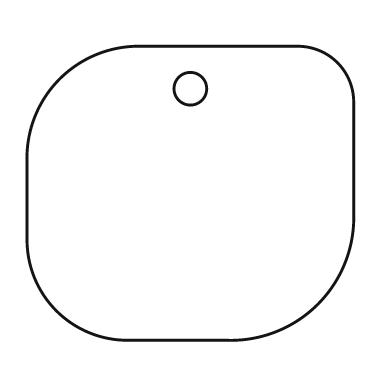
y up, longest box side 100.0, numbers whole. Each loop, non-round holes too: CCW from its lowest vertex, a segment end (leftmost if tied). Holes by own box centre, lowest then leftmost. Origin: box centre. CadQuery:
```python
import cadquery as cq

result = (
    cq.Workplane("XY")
    .moveTo(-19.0, -45.0)
    .lineTo(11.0, -45.0)
    .threePointArc((39.0, -34.0), (50.0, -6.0))
    .lineTo(50.0, 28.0)
    .threePointArc((45.0, 40.0), (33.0, 45.0))
    .lineTo(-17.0, 45.0)
    .threePointArc((-40.0, 35.0), (-50.0, 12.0))
    .lineTo(-50.0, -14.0)
    .threePointArc((-41.0, -36.0), (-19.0, -45.0))
    .close()
    .moveTo(0.0, 32.0)
    .circle(5.0)
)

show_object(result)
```